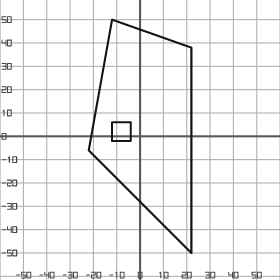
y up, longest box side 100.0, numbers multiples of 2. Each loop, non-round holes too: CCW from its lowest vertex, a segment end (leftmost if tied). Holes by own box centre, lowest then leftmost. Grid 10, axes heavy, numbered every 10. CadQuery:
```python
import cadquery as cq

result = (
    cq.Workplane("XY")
    .moveTo(22.0, -50.0)
    .lineTo(22.0, 38.0)
    .lineTo(-12.0, 50.0)
    .lineTo(-22.0, -6.0)
    .close()
    .moveTo(-12.0, -2.0)
    .lineTo(-4.0, -2.0)
    .lineTo(-4.0, 6.0)
    .lineTo(-12.0, 6.0)
    .close()
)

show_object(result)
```